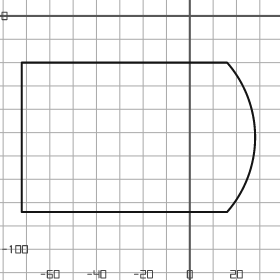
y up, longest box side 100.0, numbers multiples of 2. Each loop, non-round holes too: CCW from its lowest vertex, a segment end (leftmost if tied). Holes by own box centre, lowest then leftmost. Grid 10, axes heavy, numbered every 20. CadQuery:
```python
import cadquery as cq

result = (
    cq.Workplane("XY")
    .moveTo(-72.0, -84.0)
    .lineTo(16.0, -84.0)
    .threePointArc((28.0, -52.0), (16.0, -20.0))
    .lineTo(-72.0, -20.0)
    .close()
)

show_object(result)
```